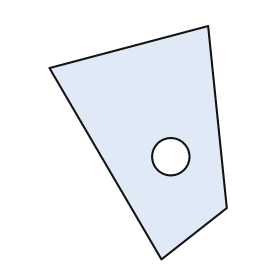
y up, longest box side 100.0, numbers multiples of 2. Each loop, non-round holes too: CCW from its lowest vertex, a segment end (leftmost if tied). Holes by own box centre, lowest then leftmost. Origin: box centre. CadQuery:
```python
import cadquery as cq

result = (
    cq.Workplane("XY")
    .moveTo(10.0, -50.0)
    .lineTo(38.0, -28.0)
    .lineTo(30.0, 50.0)
    .lineTo(-38.0, 32.0)
    .close()
    .moveTo(14.0, -6.0)
    .circle(8.0)
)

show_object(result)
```